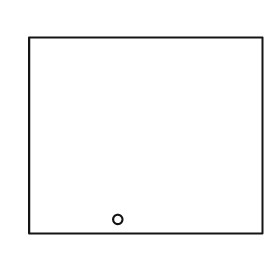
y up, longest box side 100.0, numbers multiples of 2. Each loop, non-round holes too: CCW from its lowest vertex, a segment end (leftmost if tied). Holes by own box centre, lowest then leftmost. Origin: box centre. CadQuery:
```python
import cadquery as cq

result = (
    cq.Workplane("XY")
    .moveTo(-50.0, -42.0)
    .lineTo(50.0, -42.0)
    .lineTo(50.0, 42.0)
    .lineTo(-50.0, 42.0)
    .close()
    .moveTo(-12.0, -36.0)
    .circle(2.0)
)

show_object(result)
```